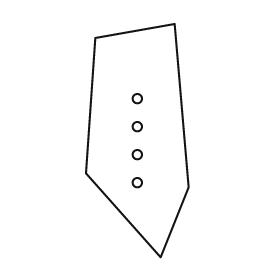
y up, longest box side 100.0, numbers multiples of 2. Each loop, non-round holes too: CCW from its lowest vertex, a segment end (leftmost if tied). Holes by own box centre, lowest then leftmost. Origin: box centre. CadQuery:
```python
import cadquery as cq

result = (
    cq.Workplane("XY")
    .moveTo(10.0, -50.0)
    .lineTo(22.0, -20.0)
    .lineTo(16.0, 50.0)
    .lineTo(-18.0, 44.0)
    .lineTo(-22.0, -14.0)
    .close()
    .moveTo(0.0, -18.0)
    .circle(2.0)
    .moveTo(0.0, -6.0)
    .circle(2.0)
    .moveTo(0.0, 6.0)
    .circle(2.0)
    .moveTo(0.0, 18.0)
    .circle(2.0)
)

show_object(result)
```